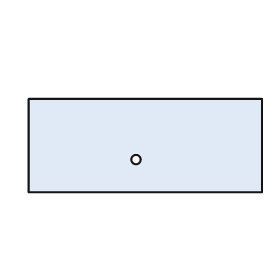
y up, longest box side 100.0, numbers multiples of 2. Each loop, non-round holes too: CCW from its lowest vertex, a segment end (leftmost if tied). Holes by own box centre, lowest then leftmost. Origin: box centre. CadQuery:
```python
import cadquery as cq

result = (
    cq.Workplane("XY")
    .moveTo(-50.0, -20.0)
    .lineTo(50.0, -20.0)
    .lineTo(50.0, 20.0)
    .lineTo(-50.0, 20.0)
    .close()
    .moveTo(-4.0, -6.0)
    .circle(2.0)
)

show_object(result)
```